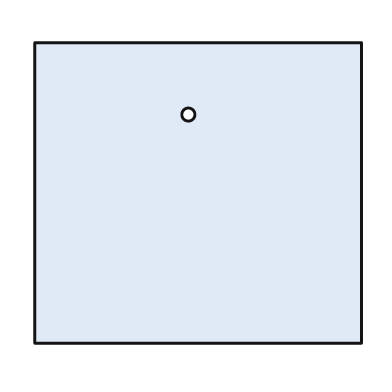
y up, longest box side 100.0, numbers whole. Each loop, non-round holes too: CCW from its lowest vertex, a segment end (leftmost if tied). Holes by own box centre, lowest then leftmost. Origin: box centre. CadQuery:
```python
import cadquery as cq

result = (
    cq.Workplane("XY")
    .moveTo(-50.0, -46.0)
    .lineTo(50.0, -46.0)
    .lineTo(50.0, 46.0)
    .lineTo(-50.0, 46.0)
    .close()
    .moveTo(-3.0, 24.0)
    .circle(2.0)
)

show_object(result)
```